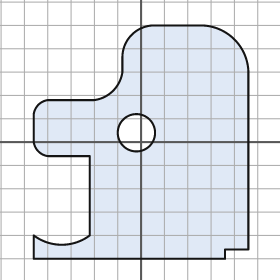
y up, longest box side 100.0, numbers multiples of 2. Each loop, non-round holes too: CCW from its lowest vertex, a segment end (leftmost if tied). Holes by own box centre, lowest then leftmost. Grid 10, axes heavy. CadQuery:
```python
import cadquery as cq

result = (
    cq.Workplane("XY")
    .moveTo(-46.0, -50.0)
    .lineTo(36.0, -50.0)
    .lineTo(36.0, -46.0)
    .lineTo(46.0, -46.0)
    .lineTo(46.0, 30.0)
    .threePointArc((40.0, 44.0), (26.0, 50.0))
    .lineTo(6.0, 50.0)
    .threePointArc((-4.0, 46.0), (-8.0, 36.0))
    .lineTo(-8.0, 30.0)
    .threePointArc((-12.0, 22.0), (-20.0, 18.0))
    .lineTo(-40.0, 18.0)
    .threePointArc((-44.0, 16.0), (-46.0, 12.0))
    .lineTo(-46.0, 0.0)
    .threePointArc((-44.0, -4.0), (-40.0, -6.0))
    .lineTo(-22.0, -6.0)
    .lineTo(-22.0, -40.0)
    .threePointArc((-34.0, -44.0), (-46.0, -40.0))
    .close()
    .moveTo(-2.0, 4.0)
    .circle(8.0)
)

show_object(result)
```